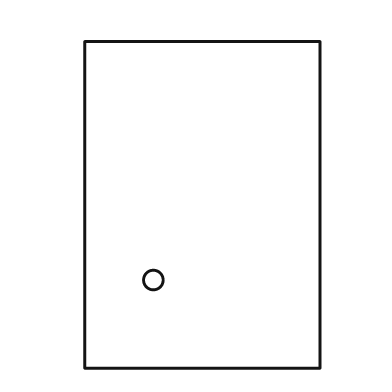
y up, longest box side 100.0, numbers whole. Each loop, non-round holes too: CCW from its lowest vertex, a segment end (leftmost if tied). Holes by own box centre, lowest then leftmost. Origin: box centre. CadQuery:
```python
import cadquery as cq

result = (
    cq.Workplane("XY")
    .moveTo(-36.0, -50.0)
    .lineTo(36.0, -50.0)
    .lineTo(36.0, 50.0)
    .lineTo(-36.0, 50.0)
    .close()
    .moveTo(-15.0, -23.0)
    .circle(3.0)
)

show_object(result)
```